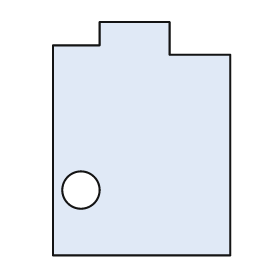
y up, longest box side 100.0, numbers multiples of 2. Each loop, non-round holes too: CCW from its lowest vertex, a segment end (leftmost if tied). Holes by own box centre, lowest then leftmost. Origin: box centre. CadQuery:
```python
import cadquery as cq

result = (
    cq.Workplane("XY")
    .moveTo(-38.0, -50.0)
    .lineTo(38.0, -50.0)
    .lineTo(38.0, 36.0)
    .lineTo(12.0, 36.0)
    .lineTo(12.0, 50.0)
    .lineTo(-18.0, 50.0)
    .lineTo(-18.0, 40.0)
    .lineTo(-38.0, 40.0)
    .close()
    .moveTo(-26.0, -22.0)
    .circle(8.0)
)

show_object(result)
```